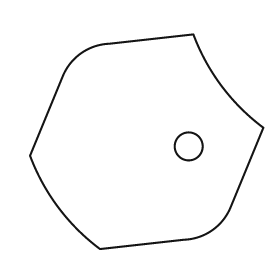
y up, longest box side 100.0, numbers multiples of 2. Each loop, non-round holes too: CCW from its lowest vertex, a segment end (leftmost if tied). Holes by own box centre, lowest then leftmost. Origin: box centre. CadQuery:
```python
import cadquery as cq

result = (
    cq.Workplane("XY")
    .moveTo(-20.0, -46.0)
    .lineTo(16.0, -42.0)
    .threePointArc((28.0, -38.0), (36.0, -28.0))
    .lineTo(50.0, 6.0)
    .threePointArc((32.0, 24.0), (20.0, 46.0))
    .lineTo(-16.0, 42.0)
    .threePointArc((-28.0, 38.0), (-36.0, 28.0))
    .lineTo(-50.0, -6.0)
    .threePointArc((-38.0, -28.0), (-20.0, -46.0))
    .close()
    .moveTo(18.0, -2.0)
    .circle(6.0)
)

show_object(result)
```